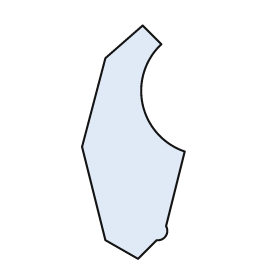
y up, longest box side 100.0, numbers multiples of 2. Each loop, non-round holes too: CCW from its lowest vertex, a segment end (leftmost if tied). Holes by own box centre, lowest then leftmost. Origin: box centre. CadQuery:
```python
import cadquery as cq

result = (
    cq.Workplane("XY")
    .moveTo(2.0, -50.0)
    .lineTo(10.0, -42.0)
    .threePointArc((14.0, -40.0), (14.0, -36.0))
    .lineTo(22.0, -4.0)
    .threePointArc((4.0, 16.0), (12.0, 42.0))
    .lineTo(4.0, 50.0)
    .lineTo(-12.0, 36.0)
    .lineTo(-22.0, -2.0)
    .lineTo(-12.0, -42.0)
    .close()
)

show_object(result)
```